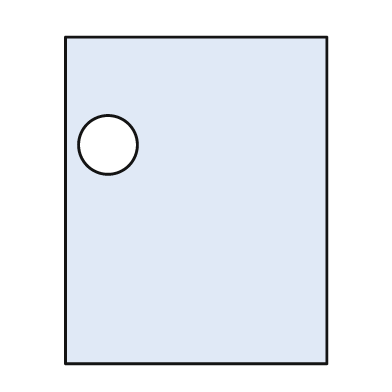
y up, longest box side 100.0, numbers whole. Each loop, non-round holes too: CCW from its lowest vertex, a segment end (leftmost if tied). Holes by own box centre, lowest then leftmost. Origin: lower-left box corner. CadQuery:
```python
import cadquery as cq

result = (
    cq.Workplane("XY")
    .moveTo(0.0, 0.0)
    .lineTo(80.0, 0.0)
    .lineTo(80.0, 100.0)
    .lineTo(0.0, 100.0)
    .close()
    .moveTo(13.0, 67.0)
    .circle(9.0)
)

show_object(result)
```